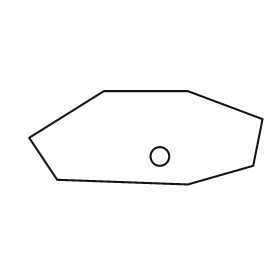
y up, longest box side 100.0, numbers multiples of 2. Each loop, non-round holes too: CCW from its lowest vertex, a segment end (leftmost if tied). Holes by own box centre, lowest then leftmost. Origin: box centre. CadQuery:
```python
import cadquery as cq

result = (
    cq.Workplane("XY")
    .moveTo(18.0, -20.0)
    .lineTo(46.0, -12.0)
    .lineTo(50.0, 8.0)
    .lineTo(18.0, 20.0)
    .lineTo(-18.0, 20.0)
    .lineTo(-50.0, 0.0)
    .lineTo(-38.0, -18.0)
    .close()
    .moveTo(6.0, -8.0)
    .circle(4.0)
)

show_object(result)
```